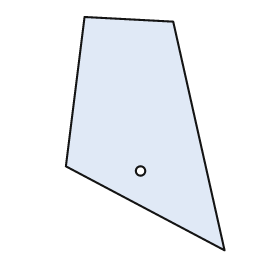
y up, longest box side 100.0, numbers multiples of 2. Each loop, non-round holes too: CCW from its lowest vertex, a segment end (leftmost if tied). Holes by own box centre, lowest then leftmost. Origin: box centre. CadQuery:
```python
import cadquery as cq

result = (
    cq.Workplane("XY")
    .moveTo(34.0, -50.0)
    .lineTo(12.0, 48.0)
    .lineTo(-26.0, 50.0)
    .lineTo(-34.0, -14.0)
    .close()
    .moveTo(-2.0, -16.0)
    .circle(2.0)
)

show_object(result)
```